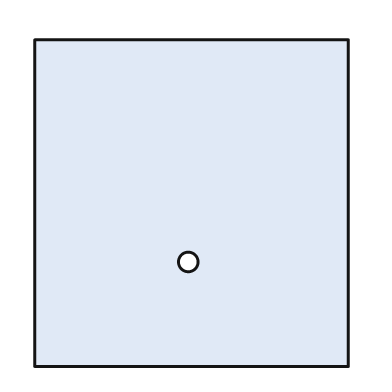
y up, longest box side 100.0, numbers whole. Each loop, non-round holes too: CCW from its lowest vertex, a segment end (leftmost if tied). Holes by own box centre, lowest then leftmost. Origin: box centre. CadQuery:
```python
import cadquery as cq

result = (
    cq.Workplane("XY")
    .moveTo(-48.0, -50.0)
    .lineTo(48.0, -50.0)
    .lineTo(48.0, 50.0)
    .lineTo(-48.0, 50.0)
    .close()
    .moveTo(-1.0, -18.0)
    .circle(3.0)
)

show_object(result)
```